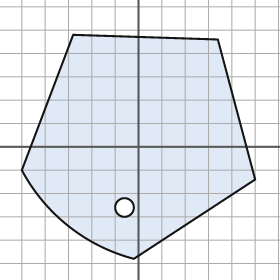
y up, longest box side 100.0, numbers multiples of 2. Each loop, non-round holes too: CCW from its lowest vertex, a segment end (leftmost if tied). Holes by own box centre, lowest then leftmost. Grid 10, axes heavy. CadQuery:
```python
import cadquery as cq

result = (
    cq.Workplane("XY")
    .moveTo(-2.0, -48.0)
    .lineTo(50.0, -14.0)
    .lineTo(34.0, 46.0)
    .lineTo(-28.0, 48.0)
    .lineTo(-50.0, -10.0)
    .threePointArc((-30.0, -34.0), (-2.0, -48.0))
    .close()
    .moveTo(-6.0, -26.0)
    .circle(4.0)
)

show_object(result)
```